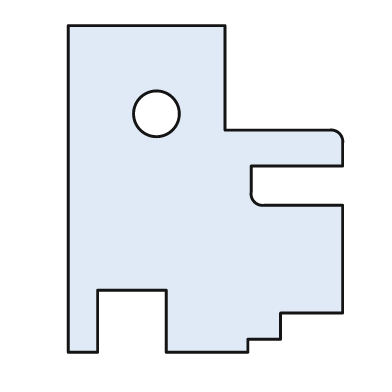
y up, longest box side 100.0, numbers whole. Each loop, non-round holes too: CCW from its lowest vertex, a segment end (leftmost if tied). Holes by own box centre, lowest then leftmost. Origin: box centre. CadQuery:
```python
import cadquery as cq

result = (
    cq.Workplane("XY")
    .moveTo(-42.0, -50.0)
    .lineTo(-33.0, -50.0)
    .lineTo(-33.0, -31.0)
    .lineTo(-12.0, -31.0)
    .lineTo(-12.0, -50.0)
    .lineTo(13.0, -50.0)
    .lineTo(13.0, -46.0)
    .lineTo(23.0, -46.0)
    .lineTo(23.0, -38.0)
    .lineTo(42.0, -38.0)
    .lineTo(42.0, -5.0)
    .lineTo(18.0, -5.0)
    .threePointArc((15.0, -4.0), (14.0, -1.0))
    .lineTo(14.0, 7.0)
    .lineTo(42.0, 7.0)
    .lineTo(42.0, 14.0)
    .threePointArc((41.0, 17.0), (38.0, 18.0))
    .lineTo(6.0, 18.0)
    .lineTo(6.0, 50.0)
    .lineTo(-42.0, 50.0)
    .close()
    .moveTo(-15.0, 23.0)
    .circle(7.0)
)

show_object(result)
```